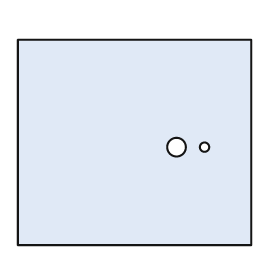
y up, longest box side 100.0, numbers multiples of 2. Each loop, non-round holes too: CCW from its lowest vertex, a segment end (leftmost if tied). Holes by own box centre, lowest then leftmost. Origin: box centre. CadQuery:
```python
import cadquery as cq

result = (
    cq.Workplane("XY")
    .moveTo(-50.0, -44.0)
    .lineTo(50.0, -44.0)
    .lineTo(50.0, 44.0)
    .lineTo(-50.0, 44.0)
    .close()
    .moveTo(18.0, -2.0)
    .circle(4.0)
    .moveTo(30.0, -2.0)
    .circle(2.0)
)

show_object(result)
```